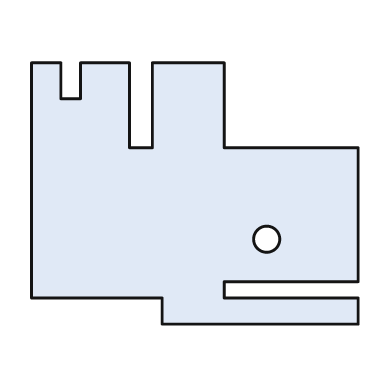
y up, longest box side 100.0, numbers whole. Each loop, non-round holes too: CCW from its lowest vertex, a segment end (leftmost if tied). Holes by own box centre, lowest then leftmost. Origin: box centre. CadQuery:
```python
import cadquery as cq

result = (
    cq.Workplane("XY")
    .moveTo(-10.0, -40.0)
    .lineTo(50.0, -40.0)
    .lineTo(50.0, -32.0)
    .lineTo(9.0, -32.0)
    .lineTo(9.0, -27.0)
    .lineTo(50.0, -27.0)
    .lineTo(50.0, 14.0)
    .lineTo(9.0, 14.0)
    .lineTo(9.0, 40.0)
    .lineTo(-13.0, 40.0)
    .lineTo(-13.0, 14.0)
    .lineTo(-20.0, 14.0)
    .lineTo(-20.0, 40.0)
    .lineTo(-35.0, 40.0)
    .lineTo(-35.0, 29.0)
    .lineTo(-41.0, 29.0)
    .lineTo(-41.0, 40.0)
    .lineTo(-50.0, 40.0)
    .lineTo(-50.0, -32.0)
    .lineTo(-10.0, -32.0)
    .close()
    .moveTo(22.0, -14.0)
    .circle(4.0)
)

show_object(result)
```